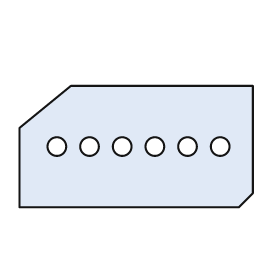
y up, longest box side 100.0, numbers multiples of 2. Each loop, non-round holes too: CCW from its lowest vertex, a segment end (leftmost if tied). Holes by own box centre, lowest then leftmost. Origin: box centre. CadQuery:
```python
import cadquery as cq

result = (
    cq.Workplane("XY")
    .moveTo(-50.0, -26.0)
    .lineTo(44.0, -26.0)
    .lineTo(50.0, -20.0)
    .lineTo(50.0, 26.0)
    .lineTo(-28.0, 26.0)
    .lineTo(-50.0, 8.0)
    .close()
    .moveTo(-34.0, 0.0)
    .circle(4.0)
    .moveTo(-20.0, 0.0)
    .circle(4.0)
    .moveTo(-6.0, 0.0)
    .circle(4.0)
    .moveTo(8.0, 0.0)
    .circle(4.0)
    .moveTo(22.0, 0.0)
    .circle(4.0)
    .moveTo(36.0, 0.0)
    .circle(4.0)
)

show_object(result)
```